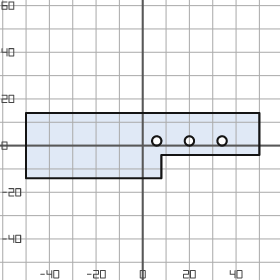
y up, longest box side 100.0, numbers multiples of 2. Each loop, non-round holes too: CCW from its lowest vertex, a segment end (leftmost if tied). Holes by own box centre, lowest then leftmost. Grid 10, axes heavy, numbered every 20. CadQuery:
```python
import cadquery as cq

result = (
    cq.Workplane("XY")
    .moveTo(-50.0, -14.0)
    .lineTo(8.0, -14.0)
    .lineTo(8.0, -4.0)
    .lineTo(50.0, -4.0)
    .lineTo(50.0, 14.0)
    .lineTo(-50.0, 14.0)
    .close()
    .moveTo(6.0, 2.0)
    .circle(2.0)
    .moveTo(20.0, 2.0)
    .circle(2.0)
    .moveTo(34.0, 2.0)
    .circle(2.0)
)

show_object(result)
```